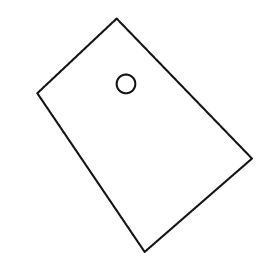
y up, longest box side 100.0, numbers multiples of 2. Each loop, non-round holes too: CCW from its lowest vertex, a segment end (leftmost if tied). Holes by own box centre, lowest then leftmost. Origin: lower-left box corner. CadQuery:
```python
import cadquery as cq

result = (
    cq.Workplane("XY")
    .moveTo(46.0, 0.0)
    .lineTo(92.0, 40.0)
    .lineTo(34.0, 100.0)
    .lineTo(0.0, 68.0)
    .close()
    .moveTo(38.0, 72.0)
    .circle(4.0)
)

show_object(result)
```